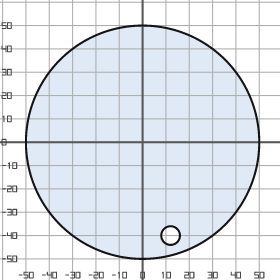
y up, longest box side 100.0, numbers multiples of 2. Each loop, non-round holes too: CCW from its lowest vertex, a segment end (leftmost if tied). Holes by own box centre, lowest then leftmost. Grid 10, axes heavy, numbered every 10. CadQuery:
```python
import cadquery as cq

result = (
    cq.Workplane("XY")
    .moveTo(0.0, 0.0)
    .circle(50.0)
    .moveTo(12.0, -40.0)
    .circle(4.0)
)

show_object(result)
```